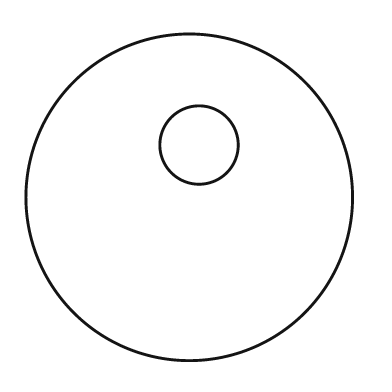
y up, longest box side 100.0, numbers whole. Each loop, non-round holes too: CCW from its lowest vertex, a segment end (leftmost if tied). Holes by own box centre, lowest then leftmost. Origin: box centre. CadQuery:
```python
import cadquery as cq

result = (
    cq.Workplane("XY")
    .moveTo(0.0, 0.0)
    .circle(50.0)
    .moveTo(3.0, 16.0)
    .circle(12.0)
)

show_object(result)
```